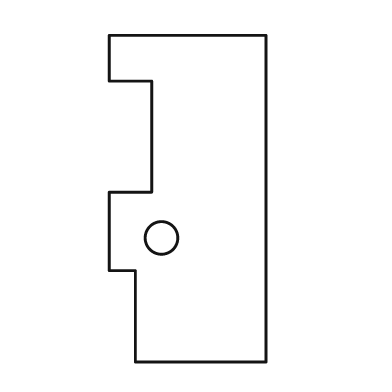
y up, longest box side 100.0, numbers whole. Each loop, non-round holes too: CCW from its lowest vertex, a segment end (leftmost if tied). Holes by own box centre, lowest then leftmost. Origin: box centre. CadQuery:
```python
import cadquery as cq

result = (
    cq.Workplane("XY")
    .moveTo(-16.0, -50.0)
    .lineTo(24.0, -50.0)
    .lineTo(24.0, 50.0)
    .lineTo(-24.0, 50.0)
    .lineTo(-24.0, 36.0)
    .lineTo(-11.0, 36.0)
    .lineTo(-11.0, 2.0)
    .lineTo(-24.0, 2.0)
    .lineTo(-24.0, -22.0)
    .lineTo(-16.0, -22.0)
    .close()
    .moveTo(-8.0, -12.0)
    .circle(5.0)
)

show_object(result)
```